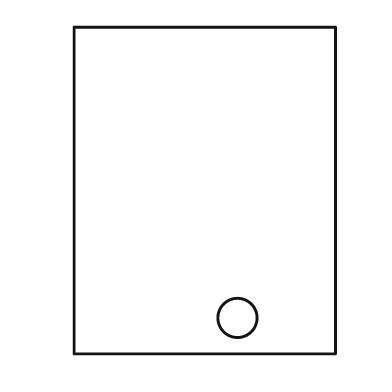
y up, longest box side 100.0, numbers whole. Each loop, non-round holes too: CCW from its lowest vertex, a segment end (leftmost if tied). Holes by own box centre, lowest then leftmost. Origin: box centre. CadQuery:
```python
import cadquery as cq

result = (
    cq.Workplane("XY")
    .moveTo(-40.0, -50.0)
    .lineTo(40.0, -50.0)
    .lineTo(40.0, 50.0)
    .lineTo(-40.0, 50.0)
    .close()
    .moveTo(10.0, -39.0)
    .circle(6.0)
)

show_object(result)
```